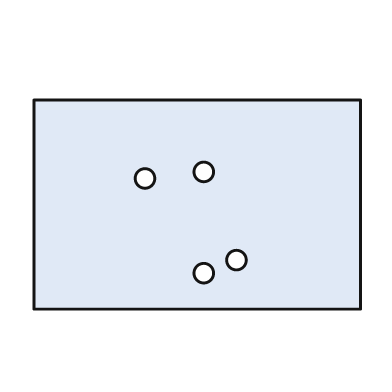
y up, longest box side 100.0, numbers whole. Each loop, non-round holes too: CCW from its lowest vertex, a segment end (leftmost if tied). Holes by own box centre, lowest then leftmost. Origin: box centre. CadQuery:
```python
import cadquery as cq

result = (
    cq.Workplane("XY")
    .moveTo(-50.0, -32.0)
    .lineTo(50.0, -32.0)
    .lineTo(50.0, 32.0)
    .lineTo(-50.0, 32.0)
    .close()
    .moveTo(2.0, -21.0)
    .circle(3.0)
    .moveTo(12.0, -17.0)
    .circle(3.0)
    .moveTo(-16.0, 8.0)
    .circle(3.0)
    .moveTo(2.0, 10.0)
    .circle(3.0)
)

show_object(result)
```